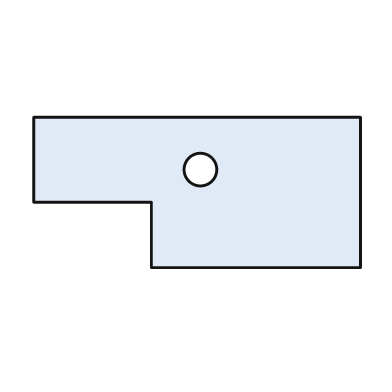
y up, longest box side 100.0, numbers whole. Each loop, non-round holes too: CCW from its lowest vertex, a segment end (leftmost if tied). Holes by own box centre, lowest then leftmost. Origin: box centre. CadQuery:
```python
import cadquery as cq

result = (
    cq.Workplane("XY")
    .moveTo(-14.0, -23.0)
    .lineTo(50.0, -23.0)
    .lineTo(50.0, 23.0)
    .lineTo(-50.0, 23.0)
    .lineTo(-50.0, -3.0)
    .lineTo(-14.0, -3.0)
    .close()
    .moveTo(1.0, 7.0)
    .circle(5.0)
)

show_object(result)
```